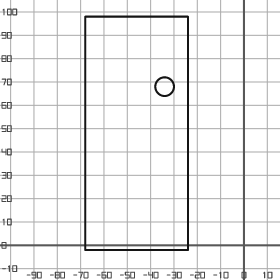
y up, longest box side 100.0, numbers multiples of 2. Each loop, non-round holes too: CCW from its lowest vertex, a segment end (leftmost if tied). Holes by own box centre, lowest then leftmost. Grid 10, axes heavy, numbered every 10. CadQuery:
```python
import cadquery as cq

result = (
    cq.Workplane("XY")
    .moveTo(-68.0, -2.0)
    .lineTo(-24.0, -2.0)
    .lineTo(-24.0, 98.0)
    .lineTo(-68.0, 98.0)
    .close()
    .moveTo(-34.0, 68.0)
    .circle(4.0)
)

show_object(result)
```